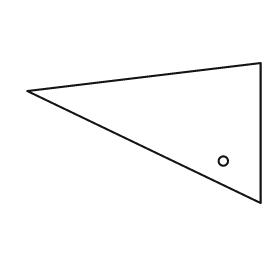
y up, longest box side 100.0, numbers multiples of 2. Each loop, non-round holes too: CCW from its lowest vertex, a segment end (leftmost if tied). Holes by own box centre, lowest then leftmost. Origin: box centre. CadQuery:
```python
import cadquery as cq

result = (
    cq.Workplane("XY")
    .moveTo(50.0, -30.0)
    .lineTo(50.0, 30.0)
    .lineTo(-50.0, 18.0)
    .close()
    .moveTo(34.0, -12.0)
    .circle(2.0)
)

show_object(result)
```